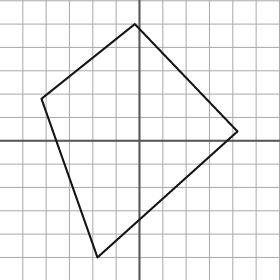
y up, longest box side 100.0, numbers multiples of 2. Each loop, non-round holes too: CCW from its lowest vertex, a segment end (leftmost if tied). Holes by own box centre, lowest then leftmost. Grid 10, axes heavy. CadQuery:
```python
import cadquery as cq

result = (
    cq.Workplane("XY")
    .moveTo(-18.0, -50.0)
    .lineTo(42.0, 4.0)
    .lineTo(-2.0, 50.0)
    .lineTo(-42.0, 18.0)
    .close()
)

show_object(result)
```